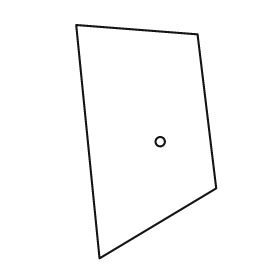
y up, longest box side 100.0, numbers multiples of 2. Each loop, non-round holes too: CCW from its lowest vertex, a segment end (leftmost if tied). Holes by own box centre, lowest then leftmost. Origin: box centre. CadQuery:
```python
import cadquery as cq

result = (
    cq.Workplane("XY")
    .moveTo(-20.0, -50.0)
    .lineTo(30.0, -20.0)
    .lineTo(22.0, 46.0)
    .lineTo(-30.0, 50.0)
    .close()
    .moveTo(6.0, 0.0)
    .circle(2.0)
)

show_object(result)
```